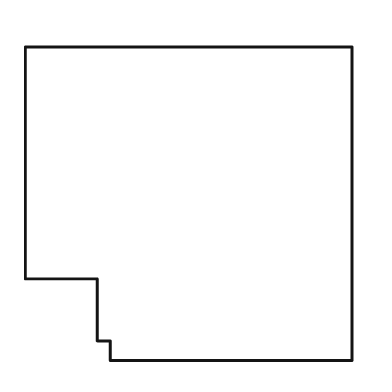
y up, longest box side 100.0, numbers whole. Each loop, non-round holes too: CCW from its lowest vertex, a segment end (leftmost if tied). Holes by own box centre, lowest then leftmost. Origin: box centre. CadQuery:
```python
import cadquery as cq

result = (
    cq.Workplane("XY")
    .moveTo(-24.0, -48.0)
    .lineTo(50.0, -48.0)
    .lineTo(50.0, 48.0)
    .lineTo(-50.0, 48.0)
    .lineTo(-50.0, -23.0)
    .lineTo(-28.0, -23.0)
    .lineTo(-28.0, -42.0)
    .lineTo(-24.0, -42.0)
    .close()
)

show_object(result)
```